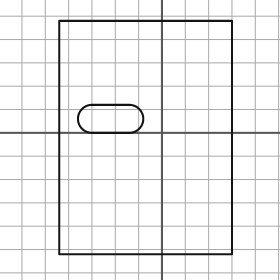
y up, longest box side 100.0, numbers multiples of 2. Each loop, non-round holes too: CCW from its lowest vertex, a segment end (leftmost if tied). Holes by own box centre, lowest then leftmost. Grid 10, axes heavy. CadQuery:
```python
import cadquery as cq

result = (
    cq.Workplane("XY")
    .moveTo(-44.0, -52.0)
    .lineTo(30.0, -52.0)
    .lineTo(30.0, 48.0)
    .lineTo(-44.0, 48.0)
    .close()
    .moveTo(-30.0, 0.0)
    .lineTo(-14.0, 0.0)
    .threePointArc((-8.0, 6.0), (-14.0, 12.0))
    .lineTo(-30.0, 12.0)
    .threePointArc((-36.0, 6.0), (-30.0, 0.0))
    .close()
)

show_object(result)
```